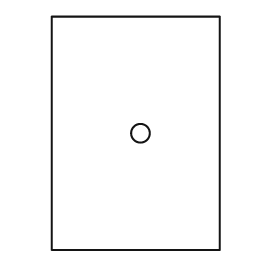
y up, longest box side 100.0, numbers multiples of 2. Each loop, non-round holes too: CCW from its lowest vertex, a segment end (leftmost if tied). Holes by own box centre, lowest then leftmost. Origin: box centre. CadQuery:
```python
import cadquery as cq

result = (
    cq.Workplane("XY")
    .moveTo(-36.0, -50.0)
    .lineTo(36.0, -50.0)
    .lineTo(36.0, 50.0)
    .lineTo(-36.0, 50.0)
    .close()
    .moveTo(2.0, 0.0)
    .circle(4.0)
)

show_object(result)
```